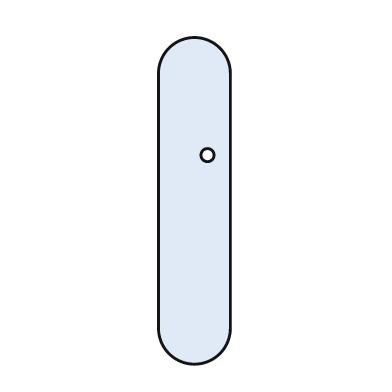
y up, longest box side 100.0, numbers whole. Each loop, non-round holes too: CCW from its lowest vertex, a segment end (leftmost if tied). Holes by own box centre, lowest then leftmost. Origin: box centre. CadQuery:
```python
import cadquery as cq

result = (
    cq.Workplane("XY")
    .moveTo(-11.0, -39.0)
    .threePointArc((0.0, -50.0), (11.0, -39.0))
    .lineTo(11.0, 39.0)
    .threePointArc((0.0, 50.0), (-11.0, 39.0))
    .close()
    .moveTo(4.0, 14.0)
    .circle(2.0)
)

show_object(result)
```